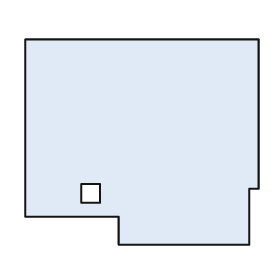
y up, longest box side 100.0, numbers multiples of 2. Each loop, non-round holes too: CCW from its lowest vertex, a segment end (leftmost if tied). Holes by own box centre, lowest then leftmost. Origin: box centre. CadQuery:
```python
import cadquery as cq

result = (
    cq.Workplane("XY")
    .moveTo(-10.0, -44.0)
    .lineTo(46.0, -44.0)
    .lineTo(46.0, -20.0)
    .lineTo(50.0, -20.0)
    .lineTo(50.0, 44.0)
    .lineTo(-50.0, 44.0)
    .lineTo(-50.0, -32.0)
    .lineTo(-10.0, -32.0)
    .close()
    .moveTo(-26.0, -26.0)
    .lineTo(-18.0, -26.0)
    .lineTo(-18.0, -18.0)
    .lineTo(-26.0, -18.0)
    .close()
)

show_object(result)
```